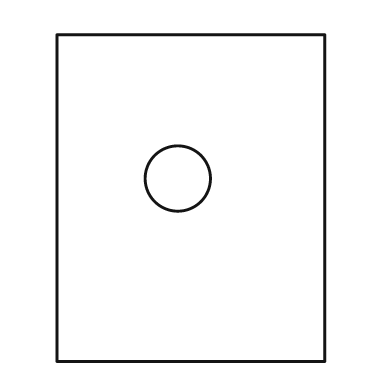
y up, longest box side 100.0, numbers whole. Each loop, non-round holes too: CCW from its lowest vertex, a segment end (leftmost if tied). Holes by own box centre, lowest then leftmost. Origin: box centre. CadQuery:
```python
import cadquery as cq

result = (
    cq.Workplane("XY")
    .moveTo(-41.0, -50.0)
    .lineTo(41.0, -50.0)
    .lineTo(41.0, 50.0)
    .lineTo(-41.0, 50.0)
    .close()
    .moveTo(-4.0, 6.0)
    .circle(10.0)
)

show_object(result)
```